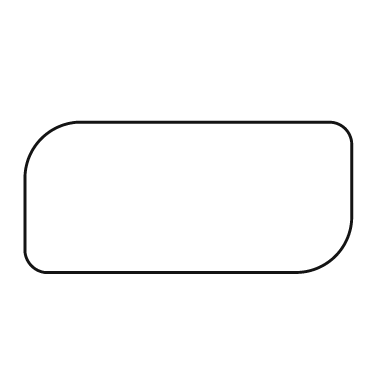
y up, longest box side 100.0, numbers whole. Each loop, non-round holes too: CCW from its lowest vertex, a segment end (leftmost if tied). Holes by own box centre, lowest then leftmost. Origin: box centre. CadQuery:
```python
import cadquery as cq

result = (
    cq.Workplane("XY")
    .moveTo(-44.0, -23.0)
    .lineTo(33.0, -23.0)
    .threePointArc((45.0, -18.0), (50.0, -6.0))
    .lineTo(50.0, 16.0)
    .threePointArc((48.0, 21.0), (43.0, 23.0))
    .lineTo(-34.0, 23.0)
    .threePointArc((-45.0, 18.0), (-50.0, 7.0))
    .lineTo(-50.0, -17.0)
    .threePointArc((-48.0, -21.0), (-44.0, -23.0))
    .close()
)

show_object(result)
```